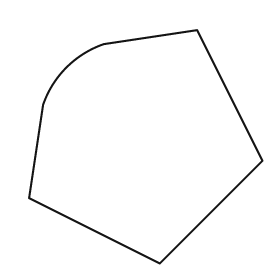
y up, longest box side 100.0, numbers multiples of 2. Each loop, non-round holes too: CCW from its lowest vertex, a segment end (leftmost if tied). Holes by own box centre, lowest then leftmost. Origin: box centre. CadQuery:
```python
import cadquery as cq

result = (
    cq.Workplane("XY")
    .moveTo(6.0, -50.0)
    .lineTo(50.0, -6.0)
    .lineTo(22.0, 50.0)
    .lineTo(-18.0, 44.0)
    .threePointArc((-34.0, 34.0), (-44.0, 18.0))
    .lineTo(-50.0, -22.0)
    .close()
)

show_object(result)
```